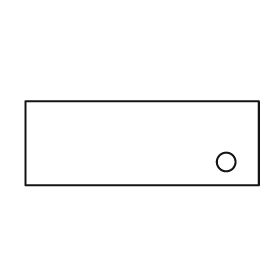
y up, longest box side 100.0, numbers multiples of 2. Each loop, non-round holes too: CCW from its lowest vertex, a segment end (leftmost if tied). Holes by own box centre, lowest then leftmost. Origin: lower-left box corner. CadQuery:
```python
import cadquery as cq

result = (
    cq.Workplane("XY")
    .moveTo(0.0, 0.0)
    .lineTo(100.0, 0.0)
    .lineTo(100.0, 36.0)
    .lineTo(0.0, 36.0)
    .close()
    .moveTo(86.0, 10.0)
    .circle(4.0)
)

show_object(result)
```